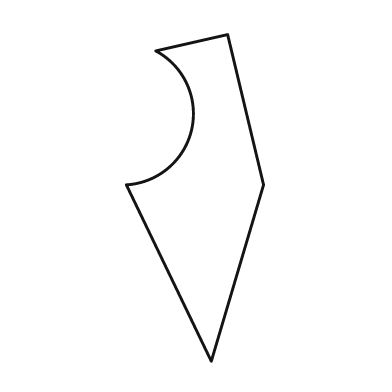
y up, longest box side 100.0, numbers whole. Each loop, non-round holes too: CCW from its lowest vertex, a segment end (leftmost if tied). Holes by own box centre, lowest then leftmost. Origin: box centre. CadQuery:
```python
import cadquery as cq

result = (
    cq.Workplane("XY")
    .moveTo(5.0, -50.0)
    .lineTo(21.0, 4.0)
    .lineTo(10.0, 50.0)
    .lineTo(-12.0, 45.0)
    .threePointArc((-1.0, 21.0), (-21.0, 4.0))
    .close()
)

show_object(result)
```